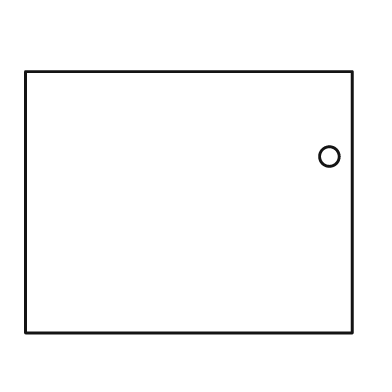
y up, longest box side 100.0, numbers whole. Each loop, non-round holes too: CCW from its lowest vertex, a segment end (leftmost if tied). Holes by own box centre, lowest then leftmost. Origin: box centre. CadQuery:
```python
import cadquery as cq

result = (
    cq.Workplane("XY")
    .moveTo(-50.0, -40.0)
    .lineTo(50.0, -40.0)
    .lineTo(50.0, 40.0)
    .lineTo(-50.0, 40.0)
    .close()
    .moveTo(43.0, 14.0)
    .circle(3.0)
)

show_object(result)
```